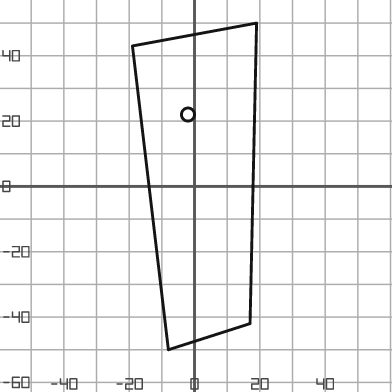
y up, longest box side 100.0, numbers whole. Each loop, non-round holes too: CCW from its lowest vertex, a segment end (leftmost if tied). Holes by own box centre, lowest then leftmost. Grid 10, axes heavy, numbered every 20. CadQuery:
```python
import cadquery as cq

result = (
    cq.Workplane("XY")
    .moveTo(-8.0, -50.0)
    .lineTo(17.0, -42.0)
    .lineTo(19.0, 50.0)
    .lineTo(-19.0, 43.0)
    .close()
    .moveTo(-2.0, 22.0)
    .circle(2.0)
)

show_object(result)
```